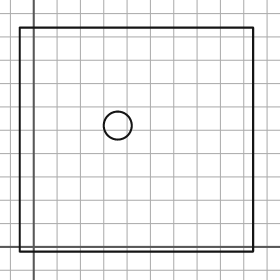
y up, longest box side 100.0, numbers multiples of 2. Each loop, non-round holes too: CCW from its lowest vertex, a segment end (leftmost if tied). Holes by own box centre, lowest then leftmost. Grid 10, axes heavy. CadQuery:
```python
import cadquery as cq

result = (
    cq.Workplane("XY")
    .moveTo(-6.0, -2.0)
    .lineTo(94.0, -2.0)
    .lineTo(94.0, 94.0)
    .lineTo(-6.0, 94.0)
    .close()
    .moveTo(36.0, 52.0)
    .circle(6.0)
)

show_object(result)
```